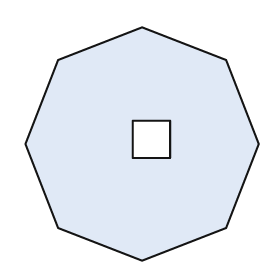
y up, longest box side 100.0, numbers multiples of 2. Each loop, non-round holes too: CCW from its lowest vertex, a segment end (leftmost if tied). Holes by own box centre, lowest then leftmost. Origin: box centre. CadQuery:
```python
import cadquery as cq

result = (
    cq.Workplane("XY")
    .moveTo(0.0, -50.0)
    .lineTo(36.0, -36.0)
    .lineTo(50.0, 0.0)
    .lineTo(36.0, 36.0)
    .lineTo(0.0, 50.0)
    .lineTo(-36.0, 36.0)
    .lineTo(-50.0, 0.0)
    .lineTo(-36.0, -36.0)
    .close()
    .moveTo(-4.0, -6.0)
    .lineTo(12.0, -6.0)
    .lineTo(12.0, 10.0)
    .lineTo(-4.0, 10.0)
    .close()
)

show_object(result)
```